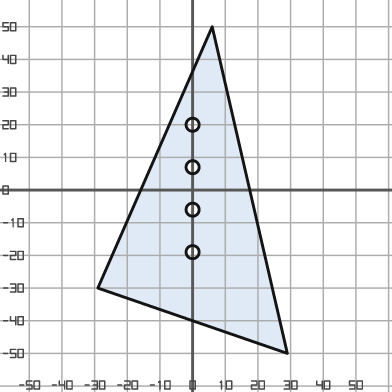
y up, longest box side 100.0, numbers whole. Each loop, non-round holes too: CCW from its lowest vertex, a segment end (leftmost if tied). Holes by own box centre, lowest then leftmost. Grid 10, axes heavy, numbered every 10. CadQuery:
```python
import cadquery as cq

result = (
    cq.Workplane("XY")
    .moveTo(29.0, -50.0)
    .lineTo(6.0, 50.0)
    .lineTo(-29.0, -30.0)
    .close()
    .moveTo(0.0, -19.0)
    .circle(2.0)
    .moveTo(0.0, -6.0)
    .circle(2.0)
    .moveTo(0.0, 7.0)
    .circle(2.0)
    .moveTo(0.0, 20.0)
    .circle(2.0)
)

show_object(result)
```